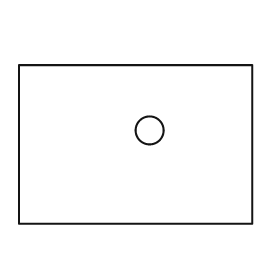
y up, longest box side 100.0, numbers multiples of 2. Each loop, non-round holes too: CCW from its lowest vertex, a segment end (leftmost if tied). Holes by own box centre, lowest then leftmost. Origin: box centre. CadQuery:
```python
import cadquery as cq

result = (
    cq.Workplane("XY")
    .moveTo(-50.0, -34.0)
    .lineTo(50.0, -34.0)
    .lineTo(50.0, 34.0)
    .lineTo(-50.0, 34.0)
    .close()
    .moveTo(6.0, 6.0)
    .circle(6.0)
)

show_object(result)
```